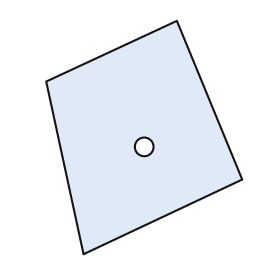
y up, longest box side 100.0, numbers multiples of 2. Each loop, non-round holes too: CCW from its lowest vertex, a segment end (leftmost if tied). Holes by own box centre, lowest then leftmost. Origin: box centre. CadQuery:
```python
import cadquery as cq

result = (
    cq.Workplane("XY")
    .moveTo(-26.0, -50.0)
    .lineTo(42.0, -18.0)
    .lineTo(14.0, 50.0)
    .lineTo(-42.0, 24.0)
    .close()
    .moveTo(0.0, -4.0)
    .circle(4.0)
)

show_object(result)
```